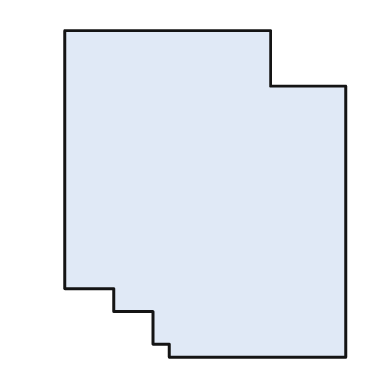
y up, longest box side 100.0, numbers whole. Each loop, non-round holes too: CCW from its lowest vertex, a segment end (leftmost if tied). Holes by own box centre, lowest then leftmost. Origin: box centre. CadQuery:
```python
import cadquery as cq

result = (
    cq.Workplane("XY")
    .moveTo(-11.0, -50.0)
    .lineTo(43.0, -50.0)
    .lineTo(43.0, 33.0)
    .lineTo(20.0, 33.0)
    .lineTo(20.0, 50.0)
    .lineTo(-43.0, 50.0)
    .lineTo(-43.0, -29.0)
    .lineTo(-28.0, -29.0)
    .lineTo(-28.0, -36.0)
    .lineTo(-16.0, -36.0)
    .lineTo(-16.0, -46.0)
    .lineTo(-11.0, -46.0)
    .close()
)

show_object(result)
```